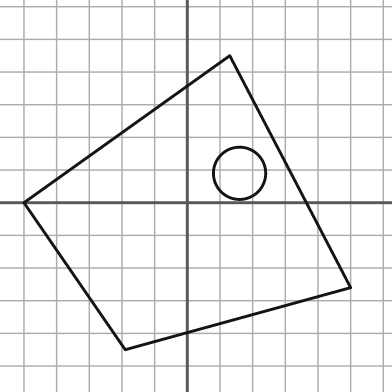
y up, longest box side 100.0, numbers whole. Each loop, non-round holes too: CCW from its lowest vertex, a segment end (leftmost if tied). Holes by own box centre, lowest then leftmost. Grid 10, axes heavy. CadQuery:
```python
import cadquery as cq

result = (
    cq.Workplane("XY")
    .moveTo(-19.0, -45.0)
    .lineTo(50.0, -26.0)
    .lineTo(13.0, 45.0)
    .lineTo(-50.0, 0.0)
    .close()
    .moveTo(16.0, 9.0)
    .circle(8.0)
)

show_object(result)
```